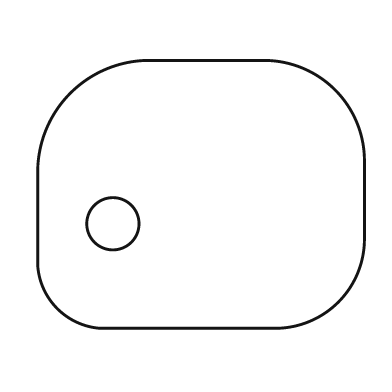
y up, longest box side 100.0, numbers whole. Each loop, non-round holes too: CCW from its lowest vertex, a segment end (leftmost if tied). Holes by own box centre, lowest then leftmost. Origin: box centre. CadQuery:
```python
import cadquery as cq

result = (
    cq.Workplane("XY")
    .moveTo(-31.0, -41.0)
    .lineTo(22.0, -41.0)
    .threePointArc((42.0, -33.0), (50.0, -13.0))
    .lineTo(50.0, 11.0)
    .threePointArc((41.0, 32.0), (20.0, 41.0))
    .lineTo(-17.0, 41.0)
    .threePointArc((-40.0, 31.0), (-50.0, 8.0))
    .lineTo(-50.0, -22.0)
    .threePointArc((-44.0, -35.0), (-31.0, -41.0))
    .close()
    .moveTo(-27.0, -9.0)
    .circle(8.0)
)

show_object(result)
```